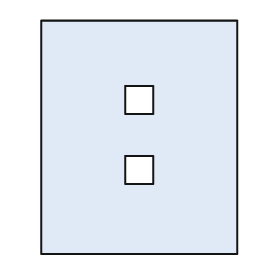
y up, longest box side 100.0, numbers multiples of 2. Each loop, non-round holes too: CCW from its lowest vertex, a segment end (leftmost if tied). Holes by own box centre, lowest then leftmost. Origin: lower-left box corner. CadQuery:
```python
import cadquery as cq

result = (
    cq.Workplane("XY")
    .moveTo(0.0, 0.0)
    .lineTo(84.0, 0.0)
    .lineTo(84.0, 100.0)
    .lineTo(0.0, 100.0)
    .close()
    .moveTo(36.0, 30.0)
    .lineTo(48.0, 30.0)
    .lineTo(48.0, 42.0)
    .lineTo(36.0, 42.0)
    .close()
    .moveTo(36.0, 60.0)
    .lineTo(48.0, 60.0)
    .lineTo(48.0, 72.0)
    .lineTo(36.0, 72.0)
    .close()
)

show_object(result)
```